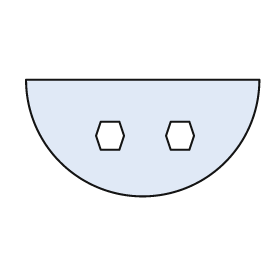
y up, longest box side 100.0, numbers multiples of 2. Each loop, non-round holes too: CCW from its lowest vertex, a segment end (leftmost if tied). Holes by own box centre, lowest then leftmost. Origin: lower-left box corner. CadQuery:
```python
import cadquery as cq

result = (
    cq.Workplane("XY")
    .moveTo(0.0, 50.0)
    .threePointArc((50.0, 0.0), (100.0, 50.0))
    .close()
    .moveTo(32.0, 20.0)
    .lineTo(40.0, 20.0)
    .lineTo(42.0, 26.0)
    .lineTo(40.0, 32.0)
    .lineTo(32.0, 32.0)
    .lineTo(30.0, 26.0)
    .close()
    .moveTo(62.0, 20.0)
    .lineTo(70.0, 20.0)
    .lineTo(72.0, 26.0)
    .lineTo(70.0, 32.0)
    .lineTo(62.0, 32.0)
    .lineTo(60.0, 26.0)
    .close()
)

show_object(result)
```